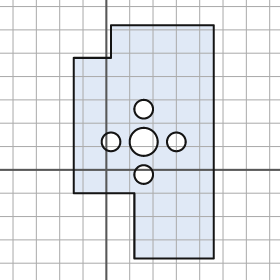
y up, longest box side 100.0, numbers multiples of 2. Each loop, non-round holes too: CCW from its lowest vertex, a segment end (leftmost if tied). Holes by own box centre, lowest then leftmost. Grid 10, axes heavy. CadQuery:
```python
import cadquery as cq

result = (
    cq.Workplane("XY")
    .moveTo(12.0, -38.0)
    .lineTo(46.0, -38.0)
    .lineTo(46.0, 62.0)
    .lineTo(2.0, 62.0)
    .lineTo(2.0, 48.0)
    .lineTo(-14.0, 48.0)
    .lineTo(-14.0, -10.0)
    .lineTo(12.0, -10.0)
    .close()
    .moveTo(16.0, -2.0)
    .circle(4.0)
    .moveTo(2.0, 12.0)
    .circle(4.0)
    .moveTo(16.0, 12.0)
    .circle(6.0)
    .moveTo(30.0, 12.0)
    .circle(4.0)
    .moveTo(16.0, 26.0)
    .circle(4.0)
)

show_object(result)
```